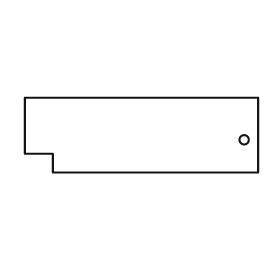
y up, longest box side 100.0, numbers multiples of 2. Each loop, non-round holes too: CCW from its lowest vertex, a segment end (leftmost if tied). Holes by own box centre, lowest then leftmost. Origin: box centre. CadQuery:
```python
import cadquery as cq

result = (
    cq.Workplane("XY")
    .moveTo(-38.0, -16.0)
    .lineTo(50.0, -16.0)
    .lineTo(50.0, 16.0)
    .lineTo(-50.0, 16.0)
    .lineTo(-50.0, -8.0)
    .lineTo(-38.0, -8.0)
    .close()
    .moveTo(44.0, -2.0)
    .circle(2.0)
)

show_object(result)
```